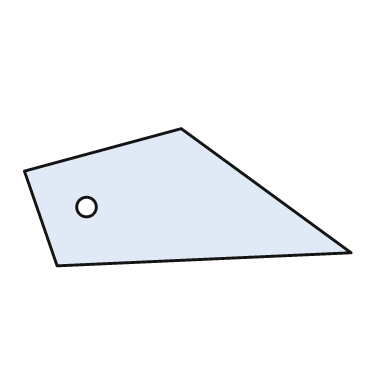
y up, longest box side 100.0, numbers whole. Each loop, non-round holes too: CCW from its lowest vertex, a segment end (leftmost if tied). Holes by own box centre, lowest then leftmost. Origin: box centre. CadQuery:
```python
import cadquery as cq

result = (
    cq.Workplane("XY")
    .moveTo(-40.0, -21.0)
    .lineTo(50.0, -17.0)
    .lineTo(-2.0, 21.0)
    .lineTo(-50.0, 8.0)
    .close()
    .moveTo(-31.0, -3.0)
    .circle(3.0)
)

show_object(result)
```